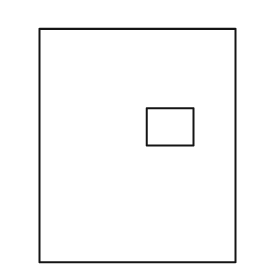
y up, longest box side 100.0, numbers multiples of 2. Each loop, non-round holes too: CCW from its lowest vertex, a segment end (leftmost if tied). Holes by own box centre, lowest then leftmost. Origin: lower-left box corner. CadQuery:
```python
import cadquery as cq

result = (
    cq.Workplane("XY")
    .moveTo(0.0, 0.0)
    .lineTo(84.0, 0.0)
    .lineTo(84.0, 100.0)
    .lineTo(0.0, 100.0)
    .close()
    .moveTo(46.0, 50.0)
    .lineTo(66.0, 50.0)
    .lineTo(66.0, 66.0)
    .lineTo(46.0, 66.0)
    .close()
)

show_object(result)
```